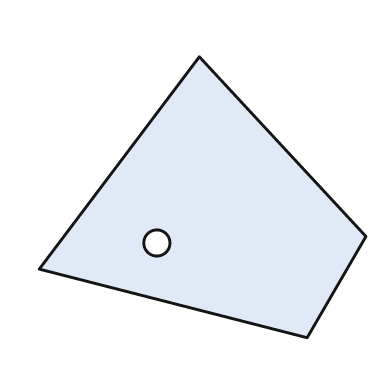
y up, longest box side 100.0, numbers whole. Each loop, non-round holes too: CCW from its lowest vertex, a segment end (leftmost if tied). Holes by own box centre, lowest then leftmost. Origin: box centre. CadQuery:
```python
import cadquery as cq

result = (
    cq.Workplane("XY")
    .moveTo(32.0, -43.0)
    .lineTo(50.0, -12.0)
    .lineTo(-1.0, 43.0)
    .lineTo(-50.0, -22.0)
    .close()
    .moveTo(-14.0, -14.0)
    .circle(4.0)
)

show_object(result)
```